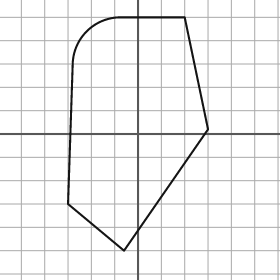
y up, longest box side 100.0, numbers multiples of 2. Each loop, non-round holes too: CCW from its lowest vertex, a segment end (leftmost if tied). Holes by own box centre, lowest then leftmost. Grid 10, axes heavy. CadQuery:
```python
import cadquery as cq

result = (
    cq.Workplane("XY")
    .moveTo(-6.0, -50.0)
    .lineTo(30.0, 2.0)
    .lineTo(20.0, 50.0)
    .lineTo(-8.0, 50.0)
    .threePointArc((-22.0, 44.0), (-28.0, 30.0))
    .lineTo(-30.0, -30.0)
    .close()
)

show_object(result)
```